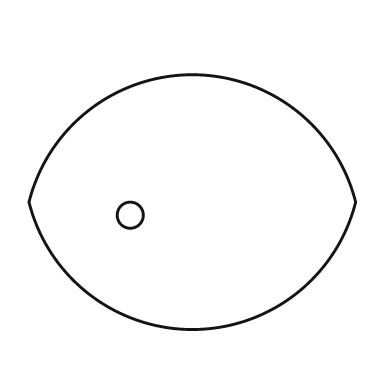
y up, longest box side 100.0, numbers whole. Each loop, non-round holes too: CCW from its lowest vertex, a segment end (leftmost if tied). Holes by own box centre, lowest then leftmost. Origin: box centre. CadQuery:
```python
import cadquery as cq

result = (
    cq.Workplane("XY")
    .moveTo(-50.0, 0.0)
    .threePointArc((0.0, -39.0), (50.0, 0.0))
    .threePointArc((0.0, 39.0), (-50.0, 0.0))
    .close()
    .moveTo(-19.0, -4.0)
    .circle(4.0)
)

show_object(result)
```